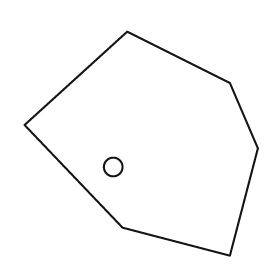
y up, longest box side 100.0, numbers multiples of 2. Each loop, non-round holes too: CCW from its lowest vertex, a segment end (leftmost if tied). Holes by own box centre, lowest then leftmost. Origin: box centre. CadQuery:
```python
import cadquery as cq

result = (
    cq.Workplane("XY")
    .moveTo(38.0, -48.0)
    .lineTo(50.0, -2.0)
    .lineTo(38.0, 26.0)
    .lineTo(-6.0, 48.0)
    .lineTo(-50.0, 8.0)
    .lineTo(-8.0, -36.0)
    .close()
    .moveTo(-12.0, -10.0)
    .circle(4.0)
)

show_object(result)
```